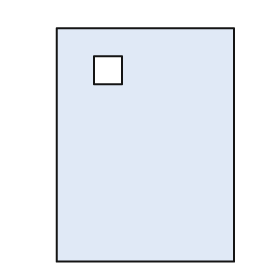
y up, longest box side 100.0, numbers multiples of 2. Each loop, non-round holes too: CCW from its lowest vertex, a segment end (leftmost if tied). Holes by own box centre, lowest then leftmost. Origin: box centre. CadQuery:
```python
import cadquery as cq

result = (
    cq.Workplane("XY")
    .moveTo(-38.0, -50.0)
    .lineTo(38.0, -50.0)
    .lineTo(38.0, 50.0)
    .lineTo(-38.0, 50.0)
    .close()
    .moveTo(-22.0, 26.0)
    .lineTo(-10.0, 26.0)
    .lineTo(-10.0, 38.0)
    .lineTo(-22.0, 38.0)
    .close()
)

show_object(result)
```